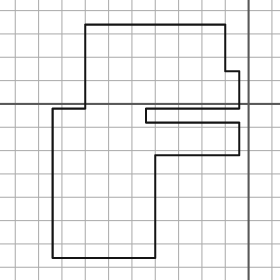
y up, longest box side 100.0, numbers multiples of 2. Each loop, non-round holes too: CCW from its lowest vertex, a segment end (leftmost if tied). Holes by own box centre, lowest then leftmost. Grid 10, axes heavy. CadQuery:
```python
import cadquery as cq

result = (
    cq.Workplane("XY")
    .moveTo(-84.0, -66.0)
    .lineTo(-40.0, -66.0)
    .lineTo(-40.0, -22.0)
    .lineTo(-4.0, -22.0)
    .lineTo(-4.0, -8.0)
    .lineTo(-44.0, -8.0)
    .lineTo(-44.0, -2.0)
    .lineTo(-4.0, -2.0)
    .lineTo(-4.0, 14.0)
    .lineTo(-10.0, 14.0)
    .lineTo(-10.0, 34.0)
    .lineTo(-70.0, 34.0)
    .lineTo(-70.0, -2.0)
    .lineTo(-84.0, -2.0)
    .close()
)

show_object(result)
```